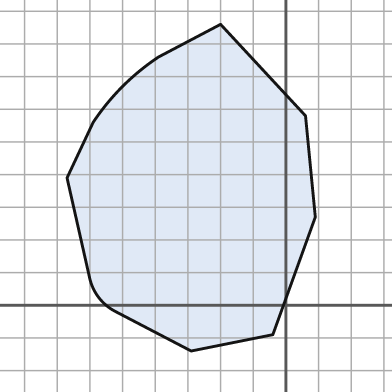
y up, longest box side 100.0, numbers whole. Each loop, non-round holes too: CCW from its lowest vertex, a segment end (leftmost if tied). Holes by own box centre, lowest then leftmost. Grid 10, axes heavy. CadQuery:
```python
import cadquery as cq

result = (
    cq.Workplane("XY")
    .moveTo(-29.0, -14.0)
    .lineTo(-4.0, -9.0)
    .lineTo(9.0, 27.0)
    .lineTo(6.0, 58.0)
    .lineTo(-20.0, 86.0)
    .lineTo(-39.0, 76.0)
    .threePointArc((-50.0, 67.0), (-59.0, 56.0))
    .lineTo(-67.0, 39.0)
    .lineTo(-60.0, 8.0)
    .threePointArc((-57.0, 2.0), (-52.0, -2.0))
    .close()
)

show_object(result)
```